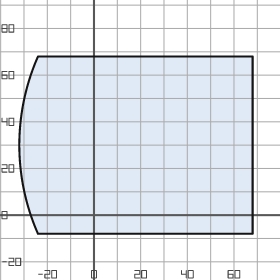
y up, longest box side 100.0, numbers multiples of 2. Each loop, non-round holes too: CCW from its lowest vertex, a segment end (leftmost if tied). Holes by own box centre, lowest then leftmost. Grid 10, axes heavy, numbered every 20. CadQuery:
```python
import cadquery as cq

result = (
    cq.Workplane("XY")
    .moveTo(-24.0, -8.0)
    .lineTo(68.0, -8.0)
    .lineTo(68.0, 68.0)
    .lineTo(-24.0, 68.0)
    .threePointArc((-32.0, 30.0), (-24.0, -8.0))
    .close()
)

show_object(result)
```